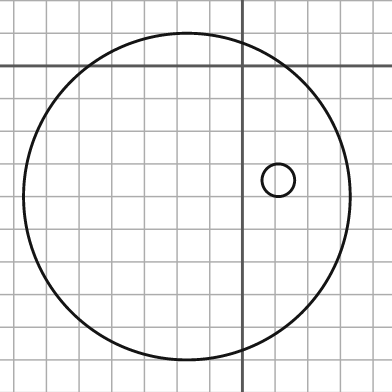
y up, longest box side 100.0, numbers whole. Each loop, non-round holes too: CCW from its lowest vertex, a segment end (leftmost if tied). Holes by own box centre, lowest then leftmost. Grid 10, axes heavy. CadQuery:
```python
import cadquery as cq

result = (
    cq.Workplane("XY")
    .moveTo(-17.0, -40.0)
    .circle(50.0)
    .moveTo(11.0, -35.0)
    .circle(5.0)
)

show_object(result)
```